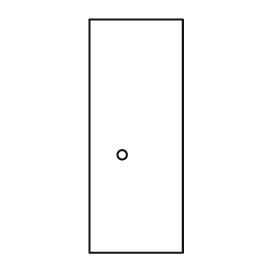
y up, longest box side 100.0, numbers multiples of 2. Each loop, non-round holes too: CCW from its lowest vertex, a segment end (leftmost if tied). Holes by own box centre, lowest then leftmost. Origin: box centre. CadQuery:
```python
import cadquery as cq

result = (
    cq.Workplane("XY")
    .moveTo(-20.0, -50.0)
    .lineTo(20.0, -50.0)
    .lineTo(20.0, 50.0)
    .lineTo(-20.0, 50.0)
    .close()
    .moveTo(-6.0, -8.0)
    .circle(2.0)
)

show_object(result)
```